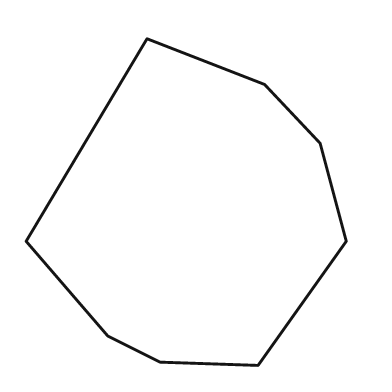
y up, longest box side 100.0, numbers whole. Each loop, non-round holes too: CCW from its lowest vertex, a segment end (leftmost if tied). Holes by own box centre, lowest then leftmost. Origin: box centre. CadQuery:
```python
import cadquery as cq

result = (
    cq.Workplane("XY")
    .moveTo(22.0, -50.0)
    .lineTo(49.0, -12.0)
    .lineTo(41.0, 18.0)
    .lineTo(24.0, 36.0)
    .lineTo(-12.0, 50.0)
    .lineTo(-49.0, -12.0)
    .lineTo(-24.0, -41.0)
    .lineTo(-8.0, -49.0)
    .close()
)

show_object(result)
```